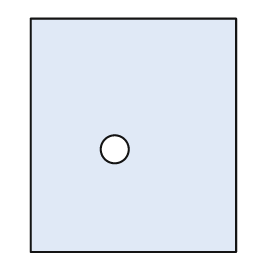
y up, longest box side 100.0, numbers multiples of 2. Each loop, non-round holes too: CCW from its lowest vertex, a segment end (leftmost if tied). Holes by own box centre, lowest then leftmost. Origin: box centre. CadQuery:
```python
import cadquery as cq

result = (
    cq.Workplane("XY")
    .moveTo(-44.0, -50.0)
    .lineTo(44.0, -50.0)
    .lineTo(44.0, 50.0)
    .lineTo(-44.0, 50.0)
    .close()
    .moveTo(-8.0, -6.0)
    .circle(6.0)
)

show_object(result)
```